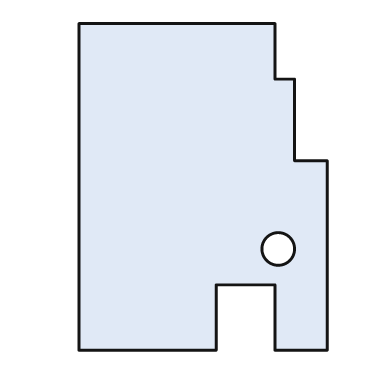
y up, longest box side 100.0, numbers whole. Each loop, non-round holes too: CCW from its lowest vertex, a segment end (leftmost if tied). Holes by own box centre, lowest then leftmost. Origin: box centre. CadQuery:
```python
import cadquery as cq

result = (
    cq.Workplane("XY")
    .moveTo(-38.0, -50.0)
    .lineTo(4.0, -50.0)
    .lineTo(4.0, -30.0)
    .lineTo(22.0, -30.0)
    .lineTo(22.0, -50.0)
    .lineTo(38.0, -50.0)
    .lineTo(38.0, 8.0)
    .lineTo(28.0, 8.0)
    .lineTo(28.0, 33.0)
    .lineTo(22.0, 33.0)
    .lineTo(22.0, 50.0)
    .lineTo(-38.0, 50.0)
    .close()
    .moveTo(23.0, -19.0)
    .circle(5.0)
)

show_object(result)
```